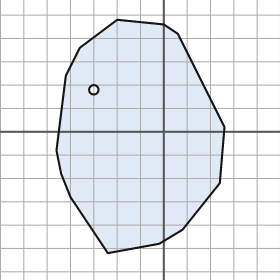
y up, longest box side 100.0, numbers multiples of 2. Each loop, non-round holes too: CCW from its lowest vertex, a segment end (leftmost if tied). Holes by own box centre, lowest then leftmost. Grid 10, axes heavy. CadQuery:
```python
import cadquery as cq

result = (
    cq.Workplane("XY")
    .moveTo(-24.0, -52.0)
    .lineTo(-2.0, -48.0)
    .lineTo(8.0, -42.0)
    .lineTo(24.0, -22.0)
    .lineTo(26.0, 2.0)
    .lineTo(6.0, 42.0)
    .lineTo(0.0, 46.0)
    .lineTo(-20.0, 48.0)
    .lineTo(-36.0, 36.0)
    .lineTo(-42.0, 24.0)
    .lineTo(-46.0, -8.0)
    .lineTo(-44.0, -18.0)
    .lineTo(-40.0, -28.0)
    .close()
    .moveTo(-30.0, 18.0)
    .circle(2.0)
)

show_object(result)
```